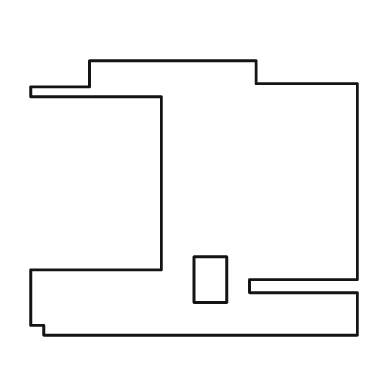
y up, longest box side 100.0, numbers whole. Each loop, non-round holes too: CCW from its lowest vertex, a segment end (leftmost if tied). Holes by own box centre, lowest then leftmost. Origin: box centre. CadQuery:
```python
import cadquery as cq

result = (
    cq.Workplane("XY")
    .moveTo(-46.0, -42.0)
    .lineTo(50.0, -42.0)
    .lineTo(50.0, -29.0)
    .lineTo(17.0, -29.0)
    .lineTo(17.0, -25.0)
    .lineTo(50.0, -25.0)
    .lineTo(50.0, 35.0)
    .lineTo(19.0, 35.0)
    .lineTo(19.0, 42.0)
    .lineTo(-32.0, 42.0)
    .lineTo(-32.0, 34.0)
    .lineTo(-50.0, 34.0)
    .lineTo(-50.0, 31.0)
    .lineTo(-10.0, 31.0)
    .lineTo(-10.0, -22.0)
    .lineTo(-50.0, -22.0)
    .lineTo(-50.0, -39.0)
    .lineTo(-46.0, -39.0)
    .close()
    .moveTo(0.0, -32.0)
    .lineTo(10.0, -32.0)
    .lineTo(10.0, -18.0)
    .lineTo(0.0, -18.0)
    .close()
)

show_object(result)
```